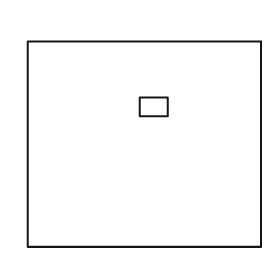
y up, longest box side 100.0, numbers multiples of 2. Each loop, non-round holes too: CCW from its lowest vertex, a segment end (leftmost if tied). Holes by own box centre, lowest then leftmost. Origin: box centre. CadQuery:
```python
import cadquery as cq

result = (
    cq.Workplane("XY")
    .moveTo(-50.0, -44.0)
    .lineTo(50.0, -44.0)
    .lineTo(50.0, 44.0)
    .lineTo(-50.0, 44.0)
    .close()
    .moveTo(-2.0, 12.0)
    .lineTo(10.0, 12.0)
    .lineTo(10.0, 20.0)
    .lineTo(-2.0, 20.0)
    .close()
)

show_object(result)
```